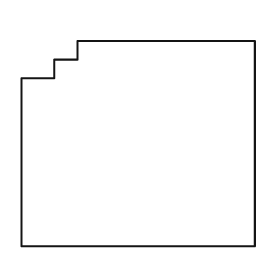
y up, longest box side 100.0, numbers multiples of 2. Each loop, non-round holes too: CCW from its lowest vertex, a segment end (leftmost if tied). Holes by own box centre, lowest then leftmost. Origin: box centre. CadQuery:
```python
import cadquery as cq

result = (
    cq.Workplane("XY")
    .moveTo(-50.0, -44.0)
    .lineTo(50.0, -44.0)
    .lineTo(50.0, 44.0)
    .lineTo(-26.0, 44.0)
    .lineTo(-26.0, 36.0)
    .lineTo(-36.0, 36.0)
    .lineTo(-36.0, 28.0)
    .lineTo(-50.0, 28.0)
    .close()
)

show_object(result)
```